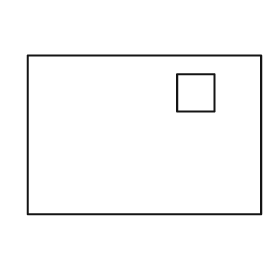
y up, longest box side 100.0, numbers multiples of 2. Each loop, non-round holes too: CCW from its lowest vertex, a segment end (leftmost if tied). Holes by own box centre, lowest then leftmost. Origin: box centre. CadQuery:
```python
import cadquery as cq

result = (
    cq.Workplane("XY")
    .moveTo(-50.0, -34.0)
    .lineTo(50.0, -34.0)
    .lineTo(50.0, 34.0)
    .lineTo(-50.0, 34.0)
    .close()
    .moveTo(14.0, 10.0)
    .lineTo(30.0, 10.0)
    .lineTo(30.0, 26.0)
    .lineTo(14.0, 26.0)
    .close()
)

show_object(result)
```